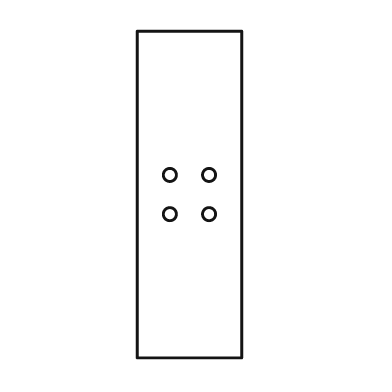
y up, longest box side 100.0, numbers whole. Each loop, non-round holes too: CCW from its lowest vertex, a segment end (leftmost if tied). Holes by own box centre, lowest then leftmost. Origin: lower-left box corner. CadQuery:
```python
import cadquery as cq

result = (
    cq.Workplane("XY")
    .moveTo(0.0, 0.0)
    .lineTo(32.0, 0.0)
    .lineTo(32.0, 100.0)
    .lineTo(0.0, 100.0)
    .close()
    .moveTo(10.0, 44.0)
    .circle(2.0)
    .moveTo(22.0, 44.0)
    .circle(2.0)
    .moveTo(10.0, 56.0)
    .circle(2.0)
    .moveTo(22.0, 56.0)
    .circle(2.0)
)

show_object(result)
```